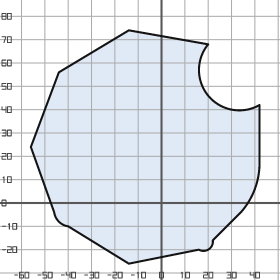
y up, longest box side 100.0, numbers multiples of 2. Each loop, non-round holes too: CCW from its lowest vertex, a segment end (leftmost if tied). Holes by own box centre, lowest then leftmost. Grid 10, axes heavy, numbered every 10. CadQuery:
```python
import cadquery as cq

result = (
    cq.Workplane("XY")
    .moveTo(-14.0, -26.0)
    .lineTo(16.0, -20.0)
    .threePointArc((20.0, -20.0), (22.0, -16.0))
    .lineTo(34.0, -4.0)
    .threePointArc((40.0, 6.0), (42.0, 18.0))
    .lineTo(42.0, 42.0)
    .threePointArc((20.0, 46.0), (20.0, 68.0))
    .lineTo(-14.0, 74.0)
    .lineTo(-44.0, 56.0)
    .lineTo(-56.0, 24.0)
    .lineTo(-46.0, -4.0)
    .threePointArc((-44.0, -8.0), (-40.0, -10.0))
    .close()
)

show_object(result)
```